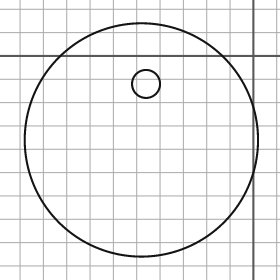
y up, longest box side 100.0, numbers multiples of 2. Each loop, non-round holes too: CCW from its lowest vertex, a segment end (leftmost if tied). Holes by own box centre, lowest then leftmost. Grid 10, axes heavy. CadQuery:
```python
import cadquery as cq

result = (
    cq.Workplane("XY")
    .moveTo(-48.0, -36.0)
    .circle(50.0)
    .moveTo(-46.0, -12.0)
    .circle(6.0)
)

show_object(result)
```